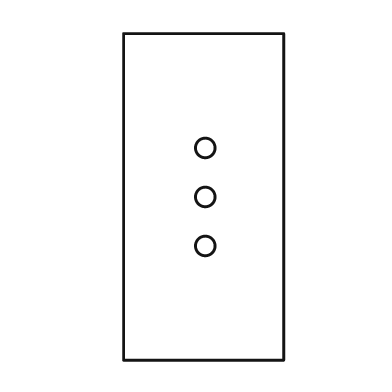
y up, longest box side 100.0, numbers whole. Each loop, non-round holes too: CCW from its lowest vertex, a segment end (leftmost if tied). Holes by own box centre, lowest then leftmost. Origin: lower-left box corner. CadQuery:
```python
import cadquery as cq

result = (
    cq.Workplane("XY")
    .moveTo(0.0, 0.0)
    .lineTo(49.0, 0.0)
    .lineTo(49.0, 100.0)
    .lineTo(0.0, 100.0)
    .close()
    .moveTo(25.0, 35.0)
    .circle(3.0)
    .moveTo(25.0, 50.0)
    .circle(3.0)
    .moveTo(25.0, 65.0)
    .circle(3.0)
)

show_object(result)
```